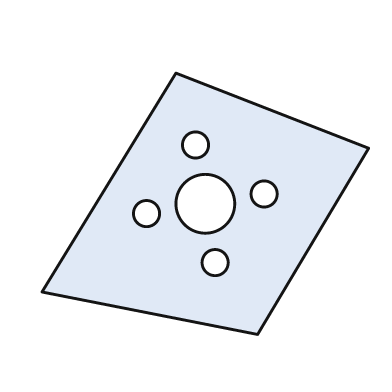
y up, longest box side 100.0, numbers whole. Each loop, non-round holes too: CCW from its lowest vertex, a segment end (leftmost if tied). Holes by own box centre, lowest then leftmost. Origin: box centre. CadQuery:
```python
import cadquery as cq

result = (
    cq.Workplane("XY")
    .moveTo(16.0, -40.0)
    .lineTo(50.0, 17.0)
    .lineTo(-9.0, 40.0)
    .lineTo(-50.0, -27.0)
    .close()
    .moveTo(3.0, -18.0)
    .circle(4.0)
    .moveTo(-18.0, -3.0)
    .circle(4.0)
    .moveTo(0.0, 0.0)
    .circle(9.0)
    .moveTo(18.0, 3.0)
    .circle(4.0)
    .moveTo(-3.0, 18.0)
    .circle(4.0)
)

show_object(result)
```